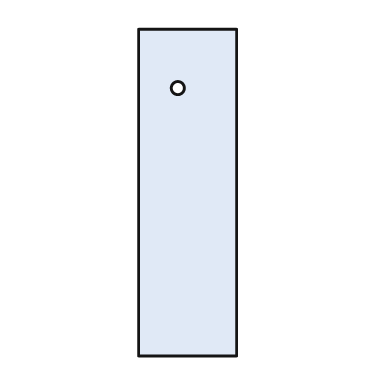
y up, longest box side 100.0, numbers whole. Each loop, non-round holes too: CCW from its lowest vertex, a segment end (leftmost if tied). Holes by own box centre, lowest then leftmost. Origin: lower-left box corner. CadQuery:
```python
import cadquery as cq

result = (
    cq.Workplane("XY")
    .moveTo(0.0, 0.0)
    .lineTo(30.0, 0.0)
    .lineTo(30.0, 100.0)
    .lineTo(0.0, 100.0)
    .close()
    .moveTo(12.0, 82.0)
    .circle(2.0)
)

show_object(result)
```